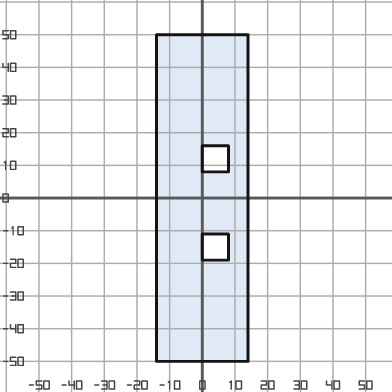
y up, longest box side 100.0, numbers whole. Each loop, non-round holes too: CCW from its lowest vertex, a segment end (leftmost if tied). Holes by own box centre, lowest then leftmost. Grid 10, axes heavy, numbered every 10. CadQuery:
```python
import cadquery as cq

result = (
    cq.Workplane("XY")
    .moveTo(-14.0, -50.0)
    .lineTo(14.0, -50.0)
    .lineTo(14.0, 50.0)
    .lineTo(-14.0, 50.0)
    .close()
    .moveTo(0.0, -19.0)
    .lineTo(8.0, -19.0)
    .lineTo(8.0, -11.0)
    .lineTo(0.0, -11.0)
    .close()
    .moveTo(0.0, 8.0)
    .lineTo(8.0, 8.0)
    .lineTo(8.0, 16.0)
    .lineTo(0.0, 16.0)
    .close()
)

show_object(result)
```